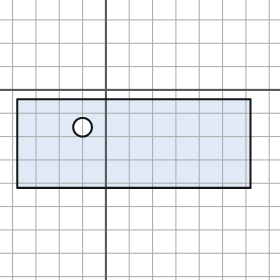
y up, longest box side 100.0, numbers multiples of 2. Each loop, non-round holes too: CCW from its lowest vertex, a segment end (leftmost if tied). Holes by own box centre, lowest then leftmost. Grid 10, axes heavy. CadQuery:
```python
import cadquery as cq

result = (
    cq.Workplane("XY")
    .moveTo(-38.0, -42.0)
    .lineTo(62.0, -42.0)
    .lineTo(62.0, -4.0)
    .lineTo(-38.0, -4.0)
    .close()
    .moveTo(-10.0, -16.0)
    .circle(4.0)
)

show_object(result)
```